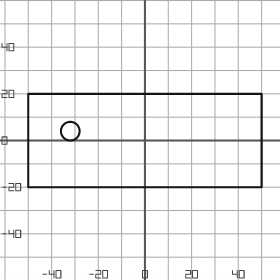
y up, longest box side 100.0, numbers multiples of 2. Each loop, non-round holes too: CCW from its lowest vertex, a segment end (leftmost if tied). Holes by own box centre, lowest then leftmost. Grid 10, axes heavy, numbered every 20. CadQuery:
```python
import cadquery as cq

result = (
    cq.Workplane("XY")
    .moveTo(-50.0, -20.0)
    .lineTo(50.0, -20.0)
    .lineTo(50.0, 20.0)
    .lineTo(-50.0, 20.0)
    .close()
    .moveTo(-32.0, 4.0)
    .circle(4.0)
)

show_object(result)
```